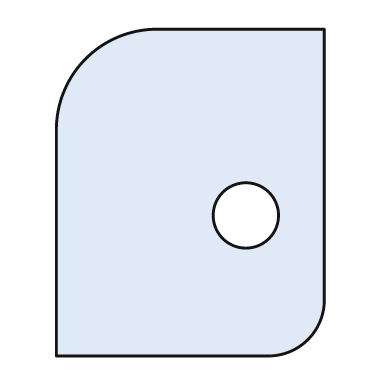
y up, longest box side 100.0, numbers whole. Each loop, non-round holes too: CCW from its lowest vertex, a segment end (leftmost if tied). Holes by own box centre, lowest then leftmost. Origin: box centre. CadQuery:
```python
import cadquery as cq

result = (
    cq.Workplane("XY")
    .moveTo(-41.0, -50.0)
    .lineTo(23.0, -50.0)
    .threePointArc((36.0, -45.0), (41.0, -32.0))
    .lineTo(41.0, 50.0)
    .lineTo(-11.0, 50.0)
    .threePointArc((-32.0, 41.0), (-41.0, 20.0))
    .close()
    .moveTo(17.0, -7.0)
    .circle(10.0)
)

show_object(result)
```